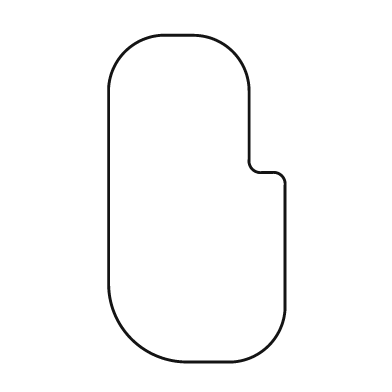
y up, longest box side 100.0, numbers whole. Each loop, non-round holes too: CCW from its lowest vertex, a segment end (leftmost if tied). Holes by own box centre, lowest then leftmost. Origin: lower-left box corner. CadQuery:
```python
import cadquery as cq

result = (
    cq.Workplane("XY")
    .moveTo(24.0, 0.0)
    .lineTo(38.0, 0.0)
    .threePointArc((49.0, 5.0), (54.0, 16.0))
    .lineTo(54.0, 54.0)
    .threePointArc((53.0, 57.0), (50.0, 58.0))
    .lineTo(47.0, 58.0)
    .threePointArc((44.0, 59.0), (43.0, 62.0))
    .lineTo(43.0, 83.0)
    .threePointArc((38.0, 95.0), (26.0, 100.0))
    .lineTo(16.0, 100.0)
    .threePointArc((5.0, 95.0), (0.0, 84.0))
    .lineTo(0.0, 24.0)
    .threePointArc((7.0, 7.0), (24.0, 0.0))
    .close()
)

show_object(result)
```